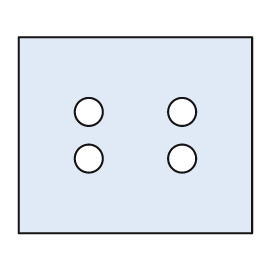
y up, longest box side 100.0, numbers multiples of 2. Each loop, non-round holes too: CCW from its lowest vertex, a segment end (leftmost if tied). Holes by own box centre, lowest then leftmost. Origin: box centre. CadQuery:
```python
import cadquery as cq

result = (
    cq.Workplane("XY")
    .moveTo(-50.0, -42.0)
    .lineTo(50.0, -42.0)
    .lineTo(50.0, 42.0)
    .lineTo(-50.0, 42.0)
    .close()
    .moveTo(-20.0, -10.0)
    .circle(6.0)
    .moveTo(20.0, -10.0)
    .circle(6.0)
    .moveTo(-20.0, 10.0)
    .circle(6.0)
    .moveTo(20.0, 10.0)
    .circle(6.0)
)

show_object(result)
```